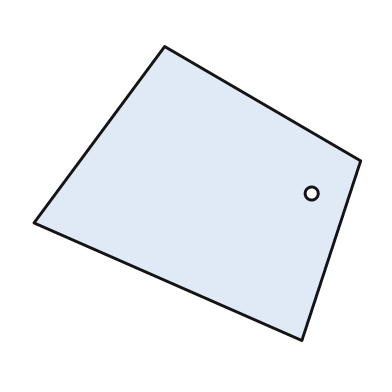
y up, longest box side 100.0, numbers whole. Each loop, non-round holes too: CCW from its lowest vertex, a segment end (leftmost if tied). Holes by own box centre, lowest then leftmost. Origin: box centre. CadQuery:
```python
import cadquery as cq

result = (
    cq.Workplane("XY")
    .moveTo(32.0, -45.0)
    .lineTo(50.0, 10.0)
    .lineTo(-10.0, 45.0)
    .lineTo(-50.0, -9.0)
    .close()
    .moveTo(35.0, 0.0)
    .circle(2.0)
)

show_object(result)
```